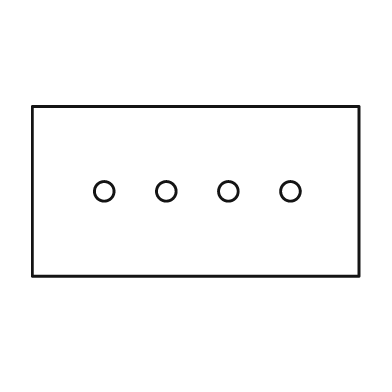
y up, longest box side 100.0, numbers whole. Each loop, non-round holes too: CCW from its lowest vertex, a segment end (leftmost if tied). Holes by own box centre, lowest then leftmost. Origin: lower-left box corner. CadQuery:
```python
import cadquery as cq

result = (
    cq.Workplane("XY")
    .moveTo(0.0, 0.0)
    .lineTo(100.0, 0.0)
    .lineTo(100.0, 52.0)
    .lineTo(0.0, 52.0)
    .close()
    .moveTo(22.0, 26.0)
    .circle(3.0)
    .moveTo(41.0, 26.0)
    .circle(3.0)
    .moveTo(60.0, 26.0)
    .circle(3.0)
    .moveTo(79.0, 26.0)
    .circle(3.0)
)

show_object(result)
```